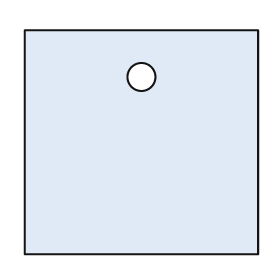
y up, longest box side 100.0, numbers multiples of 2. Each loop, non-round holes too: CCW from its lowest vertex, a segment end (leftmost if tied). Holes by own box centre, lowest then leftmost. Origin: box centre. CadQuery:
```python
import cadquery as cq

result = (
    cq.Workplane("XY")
    .moveTo(-50.0, -48.0)
    .lineTo(50.0, -48.0)
    .lineTo(50.0, 48.0)
    .lineTo(-50.0, 48.0)
    .close()
    .moveTo(0.0, 28.0)
    .circle(6.0)
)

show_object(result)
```